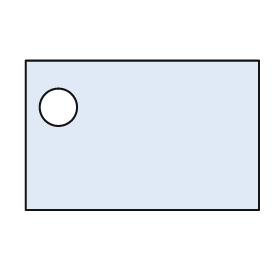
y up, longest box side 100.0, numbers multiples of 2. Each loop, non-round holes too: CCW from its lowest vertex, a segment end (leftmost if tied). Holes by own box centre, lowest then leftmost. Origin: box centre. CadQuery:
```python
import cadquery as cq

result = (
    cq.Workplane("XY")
    .moveTo(-50.0, -32.0)
    .lineTo(50.0, -32.0)
    .lineTo(50.0, 32.0)
    .lineTo(-50.0, 32.0)
    .close()
    .moveTo(-36.0, 12.0)
    .circle(8.0)
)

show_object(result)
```